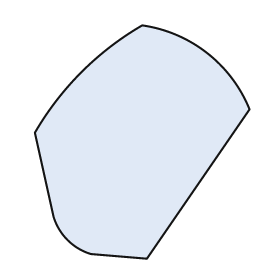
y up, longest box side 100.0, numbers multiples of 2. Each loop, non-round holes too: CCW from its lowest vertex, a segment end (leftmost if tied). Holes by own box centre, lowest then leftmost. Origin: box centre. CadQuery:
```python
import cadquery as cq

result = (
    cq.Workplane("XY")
    .moveTo(2.0, -50.0)
    .lineTo(46.0, 14.0)
    .threePointArc((28.0, 38.0), (0.0, 50.0))
    .threePointArc((-26.0, 30.0), (-46.0, 4.0))
    .lineTo(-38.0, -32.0)
    .threePointArc((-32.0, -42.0), (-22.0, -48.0))
    .close()
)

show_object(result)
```